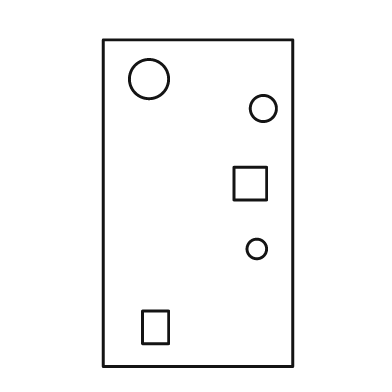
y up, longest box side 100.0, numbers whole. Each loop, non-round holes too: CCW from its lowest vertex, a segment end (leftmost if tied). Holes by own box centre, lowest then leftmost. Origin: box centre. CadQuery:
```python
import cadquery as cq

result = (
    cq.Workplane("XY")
    .moveTo(-29.0, -50.0)
    .lineTo(29.0, -50.0)
    .lineTo(29.0, 50.0)
    .lineTo(-29.0, 50.0)
    .close()
    .moveTo(-17.0, -43.0)
    .lineTo(-9.0, -43.0)
    .lineTo(-9.0, -33.0)
    .lineTo(-17.0, -33.0)
    .close()
    .moveTo(18.0, -14.0)
    .circle(3.0)
    .moveTo(11.0, 1.0)
    .lineTo(21.0, 1.0)
    .lineTo(21.0, 11.0)
    .lineTo(11.0, 11.0)
    .close()
    .moveTo(20.0, 29.0)
    .circle(4.0)
    .moveTo(-15.0, 38.0)
    .circle(6.0)
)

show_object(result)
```